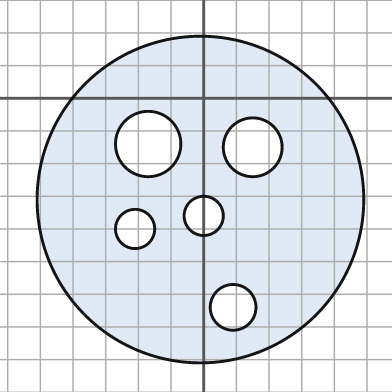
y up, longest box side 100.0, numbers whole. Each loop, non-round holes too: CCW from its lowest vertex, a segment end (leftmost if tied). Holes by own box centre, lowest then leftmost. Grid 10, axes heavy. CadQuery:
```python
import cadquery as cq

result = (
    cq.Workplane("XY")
    .moveTo(-1.0, -31.0)
    .circle(50.0)
    .moveTo(9.0, -64.0)
    .circle(7.0)
    .moveTo(-21.0, -40.0)
    .circle(6.0)
    .moveTo(0.0, -36.0)
    .circle(6.0)
    .moveTo(15.0, -15.0)
    .circle(9.0)
    .moveTo(-17.0, -14.0)
    .circle(10.0)
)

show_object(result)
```